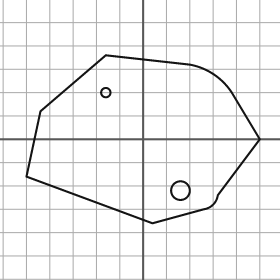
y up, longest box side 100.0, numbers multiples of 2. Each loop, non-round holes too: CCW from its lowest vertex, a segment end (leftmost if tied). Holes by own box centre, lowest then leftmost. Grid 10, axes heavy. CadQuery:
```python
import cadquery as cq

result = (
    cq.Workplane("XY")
    .moveTo(4.0, -36.0)
    .lineTo(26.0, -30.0)
    .threePointArc((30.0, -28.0), (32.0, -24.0))
    .lineTo(50.0, 0.0)
    .lineTo(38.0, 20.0)
    .threePointArc((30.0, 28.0), (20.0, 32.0))
    .lineTo(-16.0, 36.0)
    .lineTo(-44.0, 12.0)
    .lineTo(-50.0, -16.0)
    .close()
    .moveTo(16.0, -22.0)
    .circle(4.0)
    .moveTo(-16.0, 20.0)
    .circle(2.0)
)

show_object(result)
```